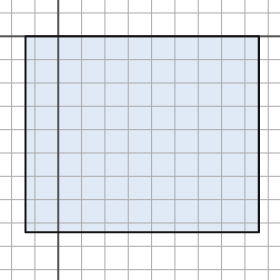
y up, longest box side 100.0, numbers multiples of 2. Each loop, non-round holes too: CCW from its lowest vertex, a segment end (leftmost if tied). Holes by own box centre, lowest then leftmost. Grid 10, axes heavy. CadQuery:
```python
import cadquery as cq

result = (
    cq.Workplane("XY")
    .moveTo(-14.0, -84.0)
    .lineTo(86.0, -84.0)
    .lineTo(86.0, 0.0)
    .lineTo(-14.0, 0.0)
    .close()
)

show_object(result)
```